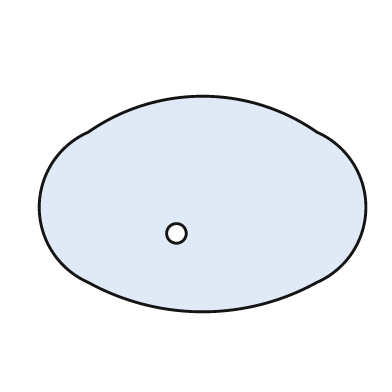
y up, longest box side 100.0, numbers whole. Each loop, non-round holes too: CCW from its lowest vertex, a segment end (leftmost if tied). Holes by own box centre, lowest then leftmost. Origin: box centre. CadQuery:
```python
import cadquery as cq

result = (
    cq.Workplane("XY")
    .moveTo(-35.0, -24.0)
    .threePointArc((0.0, -33.0), (35.0, -24.0))
    .threePointArc((50.0, -1.0), (35.0, 22.0))
    .threePointArc((0.0, 33.0), (-35.0, 22.0))
    .threePointArc((-50.0, -1.0), (-35.0, -24.0))
    .close()
    .moveTo(-8.0, -9.0)
    .circle(3.0)
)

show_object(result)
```